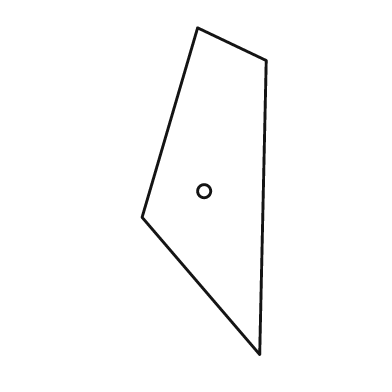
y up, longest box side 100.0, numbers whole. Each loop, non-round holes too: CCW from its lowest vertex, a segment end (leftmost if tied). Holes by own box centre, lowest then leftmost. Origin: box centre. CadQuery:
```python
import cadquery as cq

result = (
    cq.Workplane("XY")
    .moveTo(17.0, -50.0)
    .lineTo(19.0, 40.0)
    .lineTo(-2.0, 50.0)
    .lineTo(-19.0, -8.0)
    .close()
    .moveTo(0.0, 0.0)
    .circle(2.0)
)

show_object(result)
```